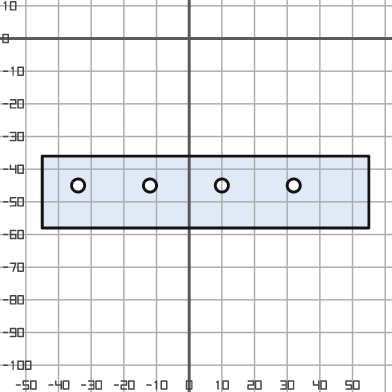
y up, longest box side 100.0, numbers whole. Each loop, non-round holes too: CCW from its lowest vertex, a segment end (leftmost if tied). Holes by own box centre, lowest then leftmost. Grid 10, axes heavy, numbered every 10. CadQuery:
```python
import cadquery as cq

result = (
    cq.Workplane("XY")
    .moveTo(-45.0, -58.0)
    .lineTo(55.0, -58.0)
    .lineTo(55.0, -36.0)
    .lineTo(-45.0, -36.0)
    .close()
    .moveTo(-34.0, -45.0)
    .circle(2.0)
    .moveTo(-12.0, -45.0)
    .circle(2.0)
    .moveTo(10.0, -45.0)
    .circle(2.0)
    .moveTo(32.0, -45.0)
    .circle(2.0)
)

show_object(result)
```